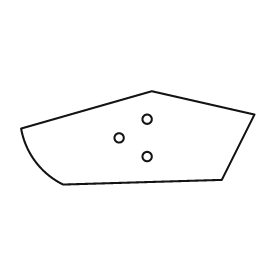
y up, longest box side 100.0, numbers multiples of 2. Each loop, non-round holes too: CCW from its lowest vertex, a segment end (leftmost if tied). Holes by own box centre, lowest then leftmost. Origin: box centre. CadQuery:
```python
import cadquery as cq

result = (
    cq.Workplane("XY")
    .moveTo(-32.0, -20.0)
    .lineTo(36.0, -18.0)
    .lineTo(50.0, 10.0)
    .lineTo(6.0, 20.0)
    .lineTo(-50.0, 4.0)
    .threePointArc((-44.0, -10.0), (-32.0, -20.0))
    .close()
    .moveTo(4.0, -8.0)
    .circle(2.0)
    .moveTo(-8.0, 0.0)
    .circle(2.0)
    .moveTo(4.0, 8.0)
    .circle(2.0)
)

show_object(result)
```